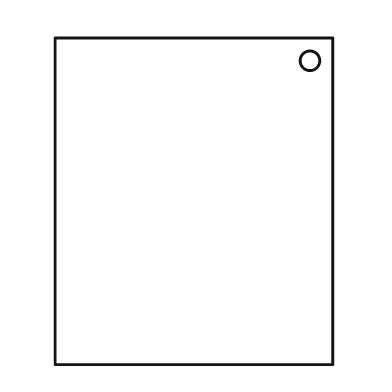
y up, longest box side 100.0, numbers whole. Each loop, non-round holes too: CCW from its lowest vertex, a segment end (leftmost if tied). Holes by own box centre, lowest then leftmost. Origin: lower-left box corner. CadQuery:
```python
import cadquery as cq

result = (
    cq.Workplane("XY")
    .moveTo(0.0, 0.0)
    .lineTo(85.0, 0.0)
    .lineTo(85.0, 100.0)
    .lineTo(0.0, 100.0)
    .close()
    .moveTo(78.0, 93.0)
    .circle(3.0)
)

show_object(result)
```